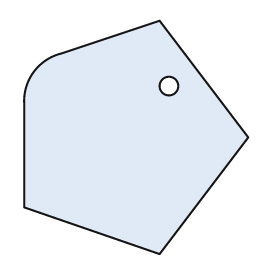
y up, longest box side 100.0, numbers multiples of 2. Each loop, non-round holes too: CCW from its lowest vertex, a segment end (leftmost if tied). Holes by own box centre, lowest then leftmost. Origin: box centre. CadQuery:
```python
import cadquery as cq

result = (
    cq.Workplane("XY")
    .moveTo(10.0, -50.0)
    .lineTo(48.0, 0.0)
    .lineTo(10.0, 50.0)
    .lineTo(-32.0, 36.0)
    .threePointArc((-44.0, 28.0), (-48.0, 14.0))
    .lineTo(-48.0, -30.0)
    .close()
    .moveTo(14.0, 22.0)
    .circle(4.0)
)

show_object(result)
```